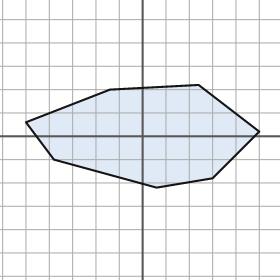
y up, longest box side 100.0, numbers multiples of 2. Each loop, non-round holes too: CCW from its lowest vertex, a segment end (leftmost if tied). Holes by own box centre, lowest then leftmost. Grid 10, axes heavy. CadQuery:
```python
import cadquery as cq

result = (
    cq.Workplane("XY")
    .moveTo(6.0, -22.0)
    .lineTo(30.0, -18.0)
    .lineTo(50.0, 2.0)
    .lineTo(24.0, 22.0)
    .lineTo(-14.0, 20.0)
    .lineTo(-50.0, 6.0)
    .lineTo(-38.0, -10.0)
    .close()
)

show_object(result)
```